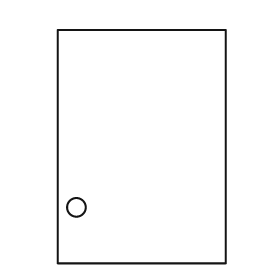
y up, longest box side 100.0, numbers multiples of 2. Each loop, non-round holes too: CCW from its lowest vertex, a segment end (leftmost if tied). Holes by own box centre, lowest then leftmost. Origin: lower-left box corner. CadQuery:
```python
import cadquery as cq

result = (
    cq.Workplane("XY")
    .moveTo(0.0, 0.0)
    .lineTo(72.0, 0.0)
    .lineTo(72.0, 100.0)
    .lineTo(0.0, 100.0)
    .close()
    .moveTo(8.0, 24.0)
    .circle(4.0)
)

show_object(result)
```